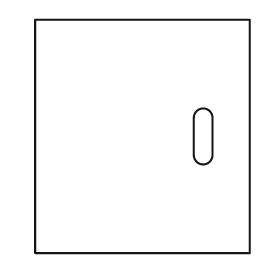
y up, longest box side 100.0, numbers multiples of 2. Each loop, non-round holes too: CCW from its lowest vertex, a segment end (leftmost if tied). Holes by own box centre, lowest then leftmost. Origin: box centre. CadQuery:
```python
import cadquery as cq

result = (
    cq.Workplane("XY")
    .moveTo(-46.0, -50.0)
    .lineTo(46.0, -50.0)
    .lineTo(46.0, 50.0)
    .lineTo(-46.0, 50.0)
    .close()
    .moveTo(22.0, -8.0)
    .threePointArc((26.0, -12.0), (30.0, -8.0))
    .lineTo(30.0, 8.0)
    .threePointArc((26.0, 12.0), (22.0, 8.0))
    .close()
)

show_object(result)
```